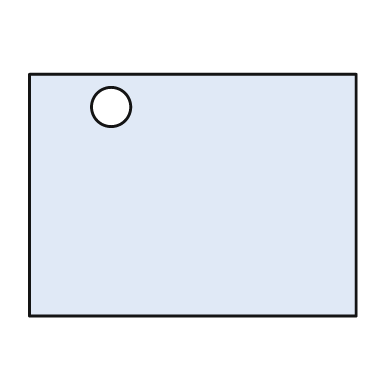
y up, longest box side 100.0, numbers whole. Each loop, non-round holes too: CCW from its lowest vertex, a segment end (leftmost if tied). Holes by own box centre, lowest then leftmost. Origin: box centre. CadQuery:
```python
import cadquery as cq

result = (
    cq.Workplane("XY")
    .moveTo(-50.0, -37.0)
    .lineTo(50.0, -37.0)
    .lineTo(50.0, 37.0)
    .lineTo(-50.0, 37.0)
    .close()
    .moveTo(-25.0, 27.0)
    .circle(6.0)
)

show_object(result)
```